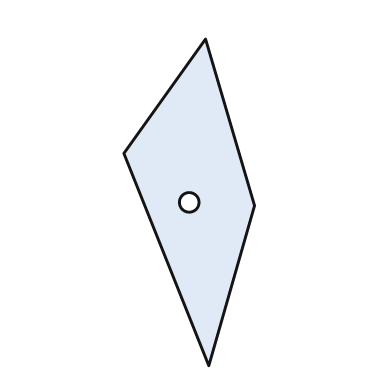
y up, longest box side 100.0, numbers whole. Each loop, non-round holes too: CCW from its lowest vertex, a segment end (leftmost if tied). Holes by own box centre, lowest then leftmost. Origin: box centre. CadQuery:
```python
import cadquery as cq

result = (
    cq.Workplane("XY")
    .moveTo(6.0, -50.0)
    .lineTo(20.0, -1.0)
    .lineTo(5.0, 50.0)
    .lineTo(-20.0, 15.0)
    .close()
    .moveTo(0.0, 0.0)
    .circle(3.0)
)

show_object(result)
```